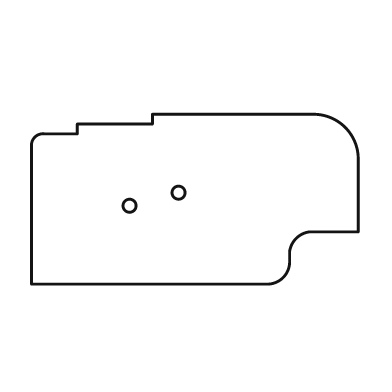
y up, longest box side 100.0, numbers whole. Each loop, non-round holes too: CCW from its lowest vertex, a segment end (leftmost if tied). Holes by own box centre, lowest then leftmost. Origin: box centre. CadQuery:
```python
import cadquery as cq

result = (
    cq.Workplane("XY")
    .moveTo(-50.0, -26.0)
    .lineTo(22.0, -26.0)
    .threePointArc((27.0, -24.0), (29.0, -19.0))
    .lineTo(29.0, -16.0)
    .threePointArc((31.0, -12.0), (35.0, -10.0))
    .lineTo(50.0, -10.0)
    .lineTo(50.0, 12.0)
    .threePointArc((46.0, 22.0), (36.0, 26.0))
    .lineTo(-13.0, 26.0)
    .lineTo(-13.0, 23.0)
    .lineTo(-36.0, 23.0)
    .lineTo(-36.0, 20.0)
    .lineTo(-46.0, 20.0)
    .threePointArc((-49.0, 19.0), (-50.0, 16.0))
    .close()
    .moveTo(-20.0, -2.0)
    .circle(2.0)
    .moveTo(-5.0, 2.0)
    .circle(2.0)
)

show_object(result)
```